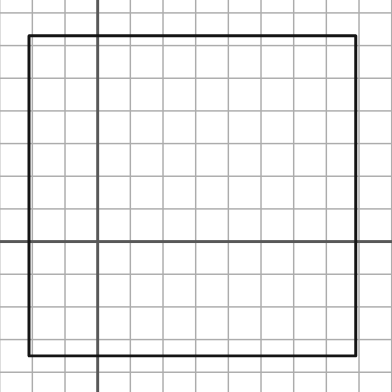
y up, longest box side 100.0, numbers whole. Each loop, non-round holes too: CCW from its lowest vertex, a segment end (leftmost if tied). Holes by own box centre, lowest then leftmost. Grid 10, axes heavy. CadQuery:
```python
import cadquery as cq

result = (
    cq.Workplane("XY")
    .moveTo(-21.0, -35.0)
    .lineTo(79.0, -35.0)
    .lineTo(79.0, 63.0)
    .lineTo(-21.0, 63.0)
    .close()
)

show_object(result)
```